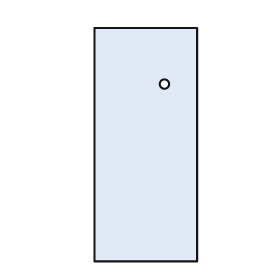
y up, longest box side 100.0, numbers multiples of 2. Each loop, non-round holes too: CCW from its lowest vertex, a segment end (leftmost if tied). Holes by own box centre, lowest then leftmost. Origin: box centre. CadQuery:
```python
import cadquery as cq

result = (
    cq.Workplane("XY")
    .moveTo(-22.0, -50.0)
    .lineTo(22.0, -50.0)
    .lineTo(22.0, 50.0)
    .lineTo(-22.0, 50.0)
    .close()
    .moveTo(8.0, 26.0)
    .circle(2.0)
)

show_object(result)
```